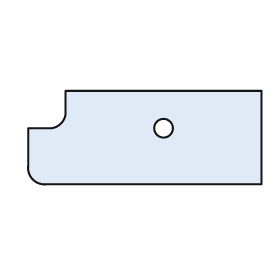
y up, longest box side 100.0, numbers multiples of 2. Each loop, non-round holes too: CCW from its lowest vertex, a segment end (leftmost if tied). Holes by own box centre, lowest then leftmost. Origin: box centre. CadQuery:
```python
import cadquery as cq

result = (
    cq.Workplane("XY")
    .moveTo(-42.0, -20.0)
    .lineTo(50.0, -20.0)
    .lineTo(50.0, 20.0)
    .lineTo(-34.0, 20.0)
    .lineTo(-34.0, 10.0)
    .threePointArc((-36.0, 6.0), (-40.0, 4.0))
    .lineTo(-50.0, 4.0)
    .lineTo(-50.0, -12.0)
    .threePointArc((-48.0, -18.0), (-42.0, -20.0))
    .close()
    .moveTo(8.0, 4.0)
    .circle(4.0)
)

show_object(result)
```